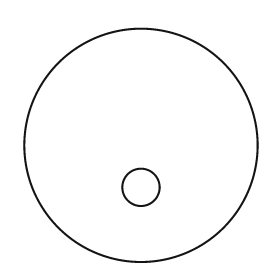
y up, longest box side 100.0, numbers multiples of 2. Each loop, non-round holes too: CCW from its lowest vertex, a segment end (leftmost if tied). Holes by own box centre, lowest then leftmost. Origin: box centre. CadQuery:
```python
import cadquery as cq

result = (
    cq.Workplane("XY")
    .moveTo(0.0, 0.0)
    .circle(50.0)
    .moveTo(0.0, -18.0)
    .circle(8.0)
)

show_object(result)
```